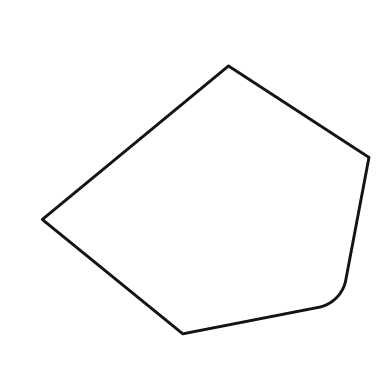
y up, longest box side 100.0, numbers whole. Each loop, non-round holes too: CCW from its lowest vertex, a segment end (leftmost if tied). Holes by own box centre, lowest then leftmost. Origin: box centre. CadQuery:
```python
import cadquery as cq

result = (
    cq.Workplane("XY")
    .moveTo(-7.0, -41.0)
    .lineTo(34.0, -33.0)
    .threePointArc((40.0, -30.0), (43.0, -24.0))
    .lineTo(50.0, 13.0)
    .lineTo(7.0, 41.0)
    .lineTo(-50.0, -6.0)
    .close()
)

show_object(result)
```